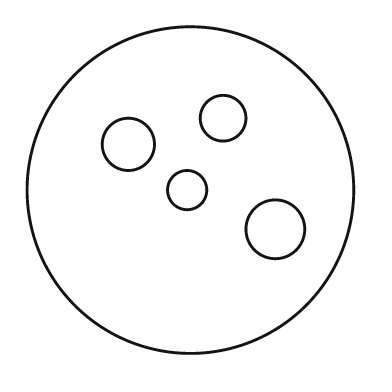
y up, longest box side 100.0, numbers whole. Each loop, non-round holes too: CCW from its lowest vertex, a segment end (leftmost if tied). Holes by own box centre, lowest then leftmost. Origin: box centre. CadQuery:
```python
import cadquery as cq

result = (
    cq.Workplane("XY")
    .moveTo(0.0, 0.0)
    .circle(50.0)
    .moveTo(26.0, -12.0)
    .circle(9.0)
    .moveTo(-1.0, 0.0)
    .circle(6.0)
    .moveTo(-19.0, 14.0)
    .circle(8.0)
    .moveTo(10.0, 22.0)
    .circle(7.0)
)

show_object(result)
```